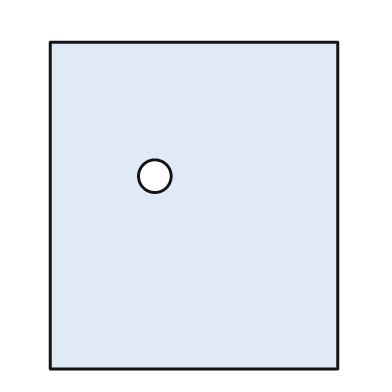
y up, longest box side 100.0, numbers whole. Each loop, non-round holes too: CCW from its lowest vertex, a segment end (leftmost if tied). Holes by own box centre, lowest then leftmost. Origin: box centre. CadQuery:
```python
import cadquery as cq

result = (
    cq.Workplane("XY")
    .moveTo(-44.0, -50.0)
    .lineTo(44.0, -50.0)
    .lineTo(44.0, 50.0)
    .lineTo(-44.0, 50.0)
    .close()
    .moveTo(-12.0, 9.0)
    .circle(5.0)
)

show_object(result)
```